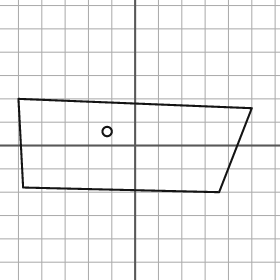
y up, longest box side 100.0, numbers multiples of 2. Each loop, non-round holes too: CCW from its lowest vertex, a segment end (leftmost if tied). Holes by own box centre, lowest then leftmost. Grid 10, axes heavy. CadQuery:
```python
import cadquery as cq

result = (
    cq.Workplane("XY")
    .moveTo(36.0, -20.0)
    .lineTo(50.0, 16.0)
    .lineTo(-50.0, 20.0)
    .lineTo(-48.0, -18.0)
    .close()
    .moveTo(-12.0, 6.0)
    .circle(2.0)
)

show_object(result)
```